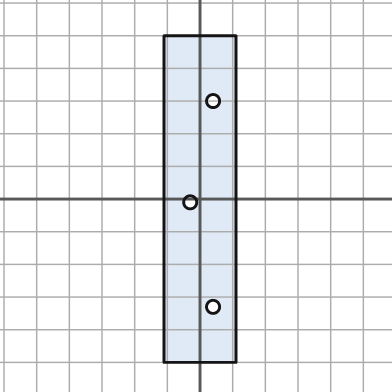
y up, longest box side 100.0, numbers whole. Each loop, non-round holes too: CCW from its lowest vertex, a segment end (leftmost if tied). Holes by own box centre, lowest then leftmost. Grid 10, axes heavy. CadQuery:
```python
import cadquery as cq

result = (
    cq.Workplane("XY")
    .moveTo(-11.0, -50.0)
    .lineTo(11.0, -50.0)
    .lineTo(11.0, 50.0)
    .lineTo(-11.0, 50.0)
    .close()
    .moveTo(4.0, -33.0)
    .circle(2.0)
    .moveTo(-3.0, -1.0)
    .circle(2.0)
    .moveTo(4.0, 30.0)
    .circle(2.0)
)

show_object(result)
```